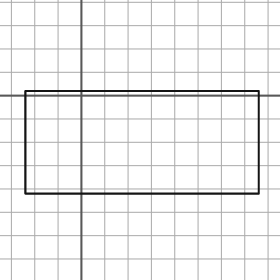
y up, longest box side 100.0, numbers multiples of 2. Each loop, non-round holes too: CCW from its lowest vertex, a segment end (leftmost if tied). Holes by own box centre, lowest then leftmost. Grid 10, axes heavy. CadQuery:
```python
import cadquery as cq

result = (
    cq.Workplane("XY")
    .moveTo(-24.0, -42.0)
    .lineTo(76.0, -42.0)
    .lineTo(76.0, 2.0)
    .lineTo(-24.0, 2.0)
    .close()
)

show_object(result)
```